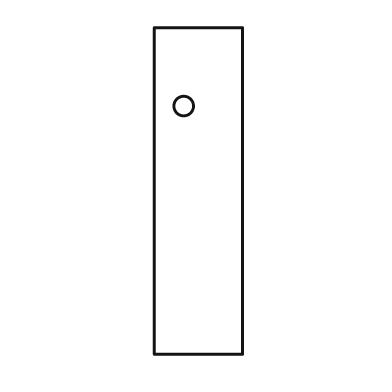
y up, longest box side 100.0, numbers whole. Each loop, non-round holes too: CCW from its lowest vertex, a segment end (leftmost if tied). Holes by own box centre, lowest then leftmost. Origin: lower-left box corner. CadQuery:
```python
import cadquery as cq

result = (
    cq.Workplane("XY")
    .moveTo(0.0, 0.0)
    .lineTo(27.0, 0.0)
    .lineTo(27.0, 100.0)
    .lineTo(0.0, 100.0)
    .close()
    .moveTo(9.0, 76.0)
    .circle(3.0)
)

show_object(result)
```